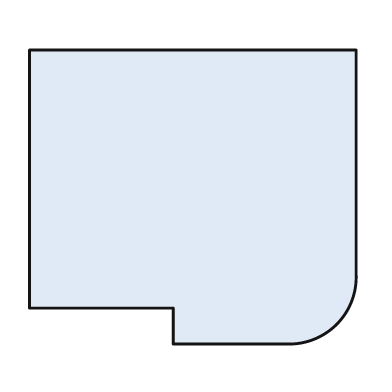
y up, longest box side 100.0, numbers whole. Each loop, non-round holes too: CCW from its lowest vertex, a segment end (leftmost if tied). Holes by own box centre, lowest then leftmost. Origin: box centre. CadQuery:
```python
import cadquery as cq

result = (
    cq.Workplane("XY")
    .moveTo(-6.0, -45.0)
    .lineTo(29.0, -45.0)
    .threePointArc((44.0, -39.0), (50.0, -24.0))
    .lineTo(50.0, 45.0)
    .lineTo(-50.0, 45.0)
    .lineTo(-50.0, -34.0)
    .lineTo(-6.0, -34.0)
    .close()
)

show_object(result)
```